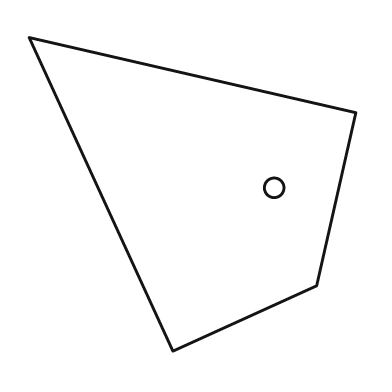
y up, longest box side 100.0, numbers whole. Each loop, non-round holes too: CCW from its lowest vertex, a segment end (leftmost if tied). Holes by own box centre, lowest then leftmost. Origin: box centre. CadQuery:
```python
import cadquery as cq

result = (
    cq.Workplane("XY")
    .moveTo(-6.0, -48.0)
    .lineTo(38.0, -28.0)
    .lineTo(50.0, 25.0)
    .lineTo(-50.0, 48.0)
    .close()
    .moveTo(25.0, 2.0)
    .circle(3.0)
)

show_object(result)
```